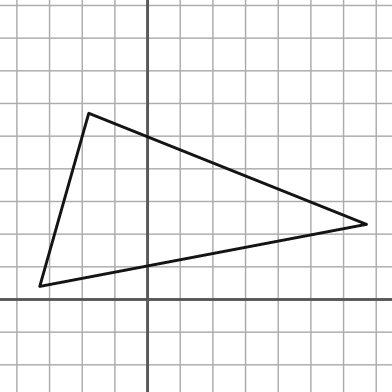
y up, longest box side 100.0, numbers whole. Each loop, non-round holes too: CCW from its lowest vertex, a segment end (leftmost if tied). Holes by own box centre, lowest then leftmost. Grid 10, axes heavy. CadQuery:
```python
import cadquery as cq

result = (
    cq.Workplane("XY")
    .moveTo(-33.0, 4.0)
    .lineTo(67.0, 23.0)
    .lineTo(-18.0, 57.0)
    .close()
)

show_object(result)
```